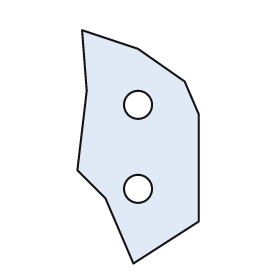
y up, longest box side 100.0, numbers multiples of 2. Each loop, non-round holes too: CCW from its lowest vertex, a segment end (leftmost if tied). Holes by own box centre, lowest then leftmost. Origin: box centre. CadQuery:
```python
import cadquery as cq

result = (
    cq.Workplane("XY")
    .moveTo(-2.0, -50.0)
    .lineTo(26.0, -32.0)
    .lineTo(26.0, 14.0)
    .lineTo(20.0, 28.0)
    .lineTo(0.0, 42.0)
    .lineTo(-24.0, 50.0)
    .lineTo(-22.0, 24.0)
    .lineTo(-26.0, -10.0)
    .lineTo(-14.0, -22.0)
    .close()
    .moveTo(0.0, -18.0)
    .circle(6.0)
    .moveTo(0.0, 18.0)
    .circle(6.0)
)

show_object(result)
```